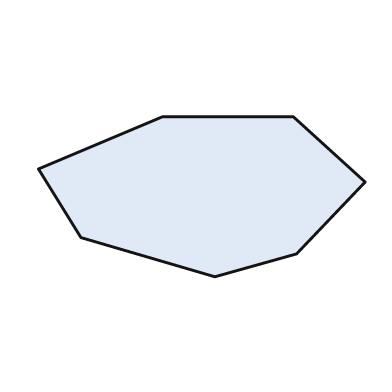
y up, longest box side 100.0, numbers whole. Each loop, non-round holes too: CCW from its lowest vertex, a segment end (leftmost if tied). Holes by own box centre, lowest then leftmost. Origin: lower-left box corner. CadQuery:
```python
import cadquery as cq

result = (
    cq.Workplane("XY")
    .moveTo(54.0, 0.0)
    .lineTo(79.0, 7.0)
    .lineTo(100.0, 29.0)
    .lineTo(78.0, 49.0)
    .lineTo(38.0, 49.0)
    .lineTo(0.0, 33.0)
    .lineTo(13.0, 12.0)
    .close()
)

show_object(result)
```